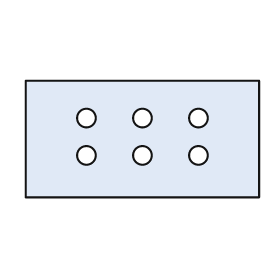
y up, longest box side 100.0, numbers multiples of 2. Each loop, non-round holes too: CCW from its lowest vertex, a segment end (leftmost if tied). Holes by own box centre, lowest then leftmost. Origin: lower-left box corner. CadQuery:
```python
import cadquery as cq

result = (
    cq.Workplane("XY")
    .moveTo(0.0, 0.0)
    .lineTo(100.0, 0.0)
    .lineTo(100.0, 50.0)
    .lineTo(0.0, 50.0)
    .close()
    .moveTo(26.0, 18.0)
    .circle(4.0)
    .moveTo(50.0, 18.0)
    .circle(4.0)
    .moveTo(74.0, 18.0)
    .circle(4.0)
    .moveTo(26.0, 34.0)
    .circle(4.0)
    .moveTo(50.0, 34.0)
    .circle(4.0)
    .moveTo(74.0, 34.0)
    .circle(4.0)
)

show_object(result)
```